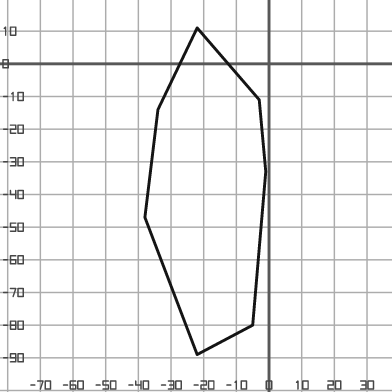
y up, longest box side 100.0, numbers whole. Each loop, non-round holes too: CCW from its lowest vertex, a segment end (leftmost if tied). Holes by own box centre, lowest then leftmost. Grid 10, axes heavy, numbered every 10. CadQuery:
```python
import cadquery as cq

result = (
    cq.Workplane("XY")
    .moveTo(-22.0, -89.0)
    .lineTo(-5.0, -80.0)
    .lineTo(-1.0, -33.0)
    .lineTo(-3.0, -11.0)
    .lineTo(-22.0, 11.0)
    .lineTo(-34.0, -14.0)
    .lineTo(-38.0, -47.0)
    .close()
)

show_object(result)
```